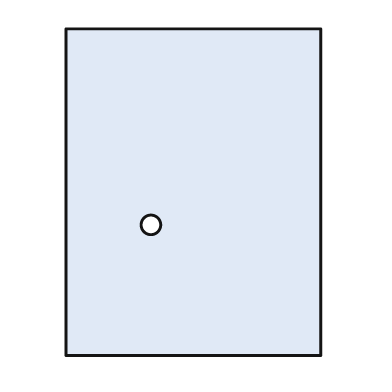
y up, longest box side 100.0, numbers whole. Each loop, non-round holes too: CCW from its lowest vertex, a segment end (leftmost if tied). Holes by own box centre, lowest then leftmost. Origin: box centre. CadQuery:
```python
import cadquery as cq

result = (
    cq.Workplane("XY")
    .moveTo(-39.0, -50.0)
    .lineTo(39.0, -50.0)
    .lineTo(39.0, 50.0)
    .lineTo(-39.0, 50.0)
    .close()
    .moveTo(-13.0, -10.0)
    .circle(3.0)
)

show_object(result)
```